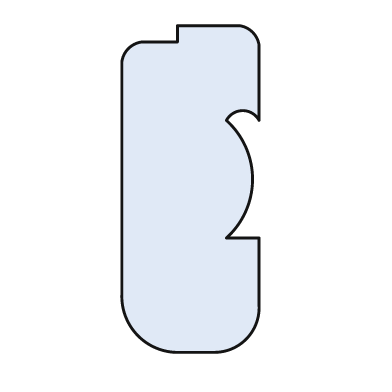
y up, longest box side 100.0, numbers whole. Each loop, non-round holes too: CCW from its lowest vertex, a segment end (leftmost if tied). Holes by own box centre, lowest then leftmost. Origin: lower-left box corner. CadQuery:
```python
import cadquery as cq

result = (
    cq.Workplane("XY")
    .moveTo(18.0, 0.0)
    .lineTo(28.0, 0.0)
    .threePointArc((38.0, 4.0), (42.0, 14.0))
    .lineTo(42.0, 35.0)
    .lineTo(32.0, 35.0)
    .threePointArc((40.0, 53.0), (32.0, 71.0))
    .threePointArc((37.0, 74.0), (42.0, 71.0))
    .lineTo(42.0, 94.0)
    .threePointArc((40.0, 98.0), (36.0, 100.0))
    .lineTo(17.0, 100.0)
    .lineTo(17.0, 95.0)
    .lineTo(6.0, 95.0)
    .threePointArc((2.0, 93.0), (0.0, 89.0))
    .lineTo(0.0, 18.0)
    .threePointArc((5.0, 5.0), (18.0, 0.0))
    .close()
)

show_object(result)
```